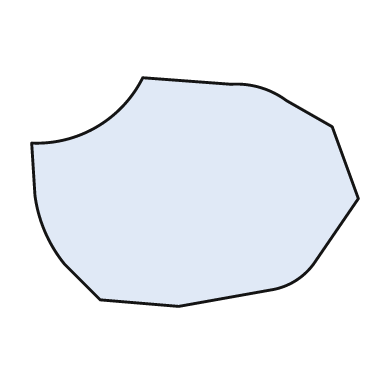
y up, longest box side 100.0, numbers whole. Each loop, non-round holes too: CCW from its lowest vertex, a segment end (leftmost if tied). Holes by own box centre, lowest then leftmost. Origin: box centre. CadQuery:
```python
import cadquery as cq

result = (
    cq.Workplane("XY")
    .moveTo(-5.0, -35.0)
    .lineTo(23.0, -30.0)
    .threePointArc((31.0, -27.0), (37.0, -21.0))
    .lineTo(50.0, -2.0)
    .lineTo(42.0, 20.0)
    .lineTo(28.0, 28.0)
    .threePointArc((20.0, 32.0), (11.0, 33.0))
    .lineTo(-16.0, 35.0)
    .threePointArc((-30.0, 20.0), (-50.0, 15.0))
    .lineTo(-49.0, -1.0)
    .threePointArc((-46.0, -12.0), (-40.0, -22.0))
    .lineTo(-29.0, -33.0)
    .close()
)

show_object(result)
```